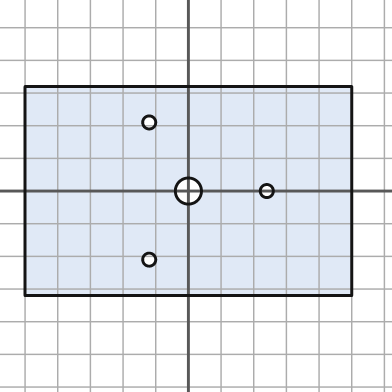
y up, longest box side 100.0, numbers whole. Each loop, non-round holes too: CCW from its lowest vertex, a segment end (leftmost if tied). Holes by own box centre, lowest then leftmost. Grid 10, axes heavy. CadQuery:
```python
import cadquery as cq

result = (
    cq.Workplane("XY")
    .moveTo(-50.0, -32.0)
    .lineTo(50.0, -32.0)
    .lineTo(50.0, 32.0)
    .lineTo(-50.0, 32.0)
    .close()
    .moveTo(-12.0, -21.0)
    .circle(2.0)
    .moveTo(0.0, 0.0)
    .circle(4.0)
    .moveTo(24.0, 0.0)
    .circle(2.0)
    .moveTo(-12.0, 21.0)
    .circle(2.0)
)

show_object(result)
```